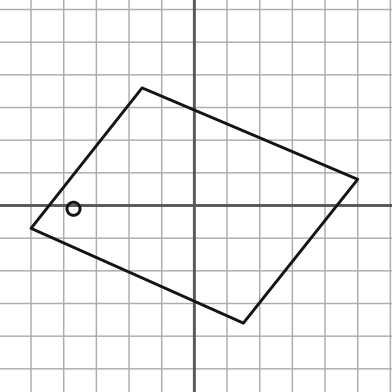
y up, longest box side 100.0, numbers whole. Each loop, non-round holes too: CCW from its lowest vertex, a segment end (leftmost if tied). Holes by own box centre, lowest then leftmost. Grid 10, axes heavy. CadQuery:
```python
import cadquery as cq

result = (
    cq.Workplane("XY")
    .moveTo(15.0, -36.0)
    .lineTo(50.0, 8.0)
    .lineTo(-16.0, 36.0)
    .lineTo(-50.0, -7.0)
    .close()
    .moveTo(-37.0, -1.0)
    .circle(2.0)
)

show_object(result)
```